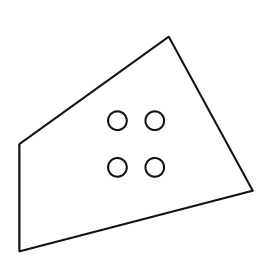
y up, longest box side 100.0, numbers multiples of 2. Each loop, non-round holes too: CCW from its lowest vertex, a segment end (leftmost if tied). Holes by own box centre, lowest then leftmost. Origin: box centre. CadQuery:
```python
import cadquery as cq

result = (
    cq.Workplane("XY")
    .moveTo(-50.0, -46.0)
    .lineTo(50.0, -20.0)
    .lineTo(14.0, 46.0)
    .lineTo(-50.0, 0.0)
    .close()
    .moveTo(-8.0, -10.0)
    .circle(4.0)
    .moveTo(8.0, -10.0)
    .circle(4.0)
    .moveTo(-8.0, 10.0)
    .circle(4.0)
    .moveTo(8.0, 10.0)
    .circle(4.0)
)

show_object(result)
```